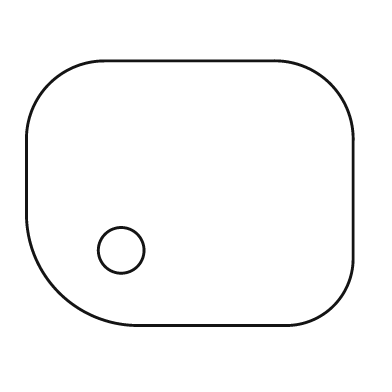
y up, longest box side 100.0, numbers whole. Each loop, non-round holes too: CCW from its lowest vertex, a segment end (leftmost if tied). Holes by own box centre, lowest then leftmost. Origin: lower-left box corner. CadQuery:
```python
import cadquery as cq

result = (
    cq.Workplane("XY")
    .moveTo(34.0, 0.0)
    .lineTo(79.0, 0.0)
    .threePointArc((94.0, 6.0), (100.0, 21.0))
    .lineTo(100.0, 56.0)
    .threePointArc((93.0, 74.0), (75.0, 81.0))
    .lineTo(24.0, 81.0)
    .threePointArc((7.0, 74.0), (0.0, 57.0))
    .lineTo(0.0, 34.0)
    .threePointArc((10.0, 10.0), (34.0, 0.0))
    .close()
    .moveTo(29.0, 23.0)
    .circle(7.0)
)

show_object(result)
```